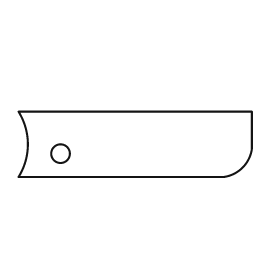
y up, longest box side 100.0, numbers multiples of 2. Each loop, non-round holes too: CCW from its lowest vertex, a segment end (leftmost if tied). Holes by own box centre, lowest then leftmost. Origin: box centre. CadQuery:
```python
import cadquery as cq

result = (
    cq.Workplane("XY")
    .moveTo(-50.0, -14.0)
    .lineTo(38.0, -14.0)
    .threePointArc((46.0, -10.0), (50.0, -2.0))
    .lineTo(50.0, 14.0)
    .lineTo(-50.0, 14.0)
    .threePointArc((-46.0, 0.0), (-50.0, -14.0))
    .close()
    .moveTo(-32.0, -4.0)
    .circle(4.0)
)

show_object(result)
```